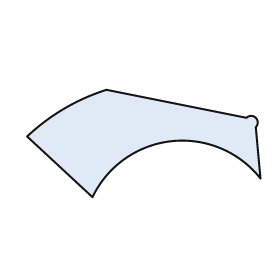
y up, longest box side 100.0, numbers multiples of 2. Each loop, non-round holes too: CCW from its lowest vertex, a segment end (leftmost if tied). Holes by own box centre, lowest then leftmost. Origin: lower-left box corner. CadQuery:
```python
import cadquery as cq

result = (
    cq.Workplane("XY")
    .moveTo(28.0, 0.0)
    .threePointArc((62.0, 24.0), (100.0, 8.0))
    .lineTo(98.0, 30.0)
    .threePointArc((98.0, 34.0), (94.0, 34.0))
    .lineTo(34.0, 46.0)
    .threePointArc((16.0, 38.0), (0.0, 26.0))
    .close()
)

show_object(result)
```